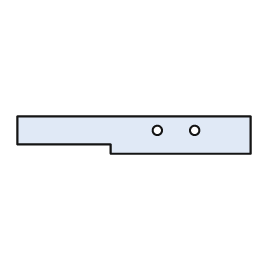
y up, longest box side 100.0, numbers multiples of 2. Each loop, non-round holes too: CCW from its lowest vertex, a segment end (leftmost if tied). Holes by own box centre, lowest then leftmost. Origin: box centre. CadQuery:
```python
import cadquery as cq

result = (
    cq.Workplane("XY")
    .moveTo(-10.0, -8.0)
    .lineTo(50.0, -8.0)
    .lineTo(50.0, 8.0)
    .lineTo(-50.0, 8.0)
    .lineTo(-50.0, -4.0)
    .lineTo(-10.0, -4.0)
    .close()
    .moveTo(10.0, 2.0)
    .circle(2.0)
    .moveTo(26.0, 2.0)
    .circle(2.0)
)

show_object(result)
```